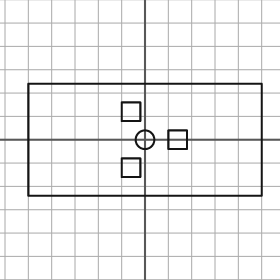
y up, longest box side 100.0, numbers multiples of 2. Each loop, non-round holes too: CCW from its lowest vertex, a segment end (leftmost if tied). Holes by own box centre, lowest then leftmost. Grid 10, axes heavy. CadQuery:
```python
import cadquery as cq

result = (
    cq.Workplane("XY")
    .moveTo(-50.0, -24.0)
    .lineTo(50.0, -24.0)
    .lineTo(50.0, 24.0)
    .lineTo(-50.0, 24.0)
    .close()
    .moveTo(-10.0, -16.0)
    .lineTo(-2.0, -16.0)
    .lineTo(-2.0, -8.0)
    .lineTo(-10.0, -8.0)
    .close()
    .moveTo(0.0, 0.0)
    .circle(4.0)
    .moveTo(10.0, -4.0)
    .lineTo(18.0, -4.0)
    .lineTo(18.0, 4.0)
    .lineTo(10.0, 4.0)
    .close()
    .moveTo(-10.0, 8.0)
    .lineTo(-2.0, 8.0)
    .lineTo(-2.0, 16.0)
    .lineTo(-10.0, 16.0)
    .close()
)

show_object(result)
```